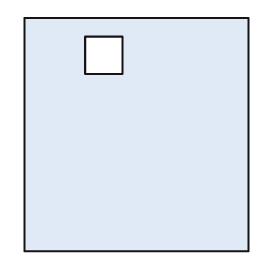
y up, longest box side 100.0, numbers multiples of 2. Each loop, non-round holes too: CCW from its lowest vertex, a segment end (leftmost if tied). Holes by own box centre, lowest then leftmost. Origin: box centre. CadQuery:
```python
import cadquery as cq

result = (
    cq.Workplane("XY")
    .moveTo(-48.0, -50.0)
    .lineTo(48.0, -50.0)
    .lineTo(48.0, 50.0)
    .lineTo(-48.0, 50.0)
    .close()
    .moveTo(-22.0, 26.0)
    .lineTo(-6.0, 26.0)
    .lineTo(-6.0, 42.0)
    .lineTo(-22.0, 42.0)
    .close()
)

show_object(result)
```